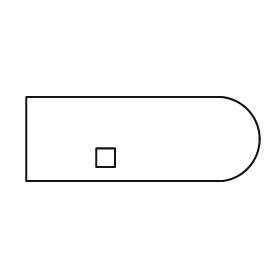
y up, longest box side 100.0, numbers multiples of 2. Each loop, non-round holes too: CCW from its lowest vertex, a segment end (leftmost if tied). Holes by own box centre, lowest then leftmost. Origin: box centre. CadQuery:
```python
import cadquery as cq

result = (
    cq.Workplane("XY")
    .moveTo(-50.0, -18.0)
    .lineTo(34.0, -18.0)
    .threePointArc((50.0, 0.0), (34.0, 18.0))
    .lineTo(-50.0, 18.0)
    .close()
    .moveTo(-20.0, -12.0)
    .lineTo(-12.0, -12.0)
    .lineTo(-12.0, -4.0)
    .lineTo(-20.0, -4.0)
    .close()
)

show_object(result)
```